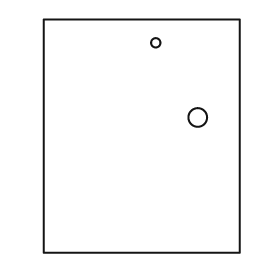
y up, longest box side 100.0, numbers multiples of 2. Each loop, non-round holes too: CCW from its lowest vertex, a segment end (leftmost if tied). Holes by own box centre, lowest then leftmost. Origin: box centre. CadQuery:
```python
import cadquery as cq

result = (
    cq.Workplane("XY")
    .moveTo(-42.0, -50.0)
    .lineTo(42.0, -50.0)
    .lineTo(42.0, 50.0)
    .lineTo(-42.0, 50.0)
    .close()
    .moveTo(24.0, 8.0)
    .circle(4.0)
    .moveTo(6.0, 40.0)
    .circle(2.0)
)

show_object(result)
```